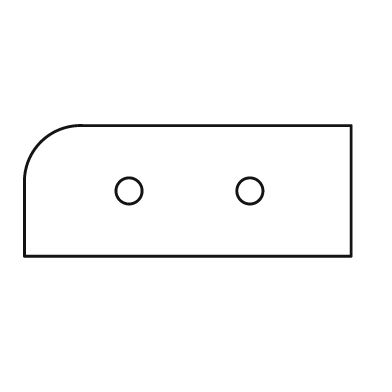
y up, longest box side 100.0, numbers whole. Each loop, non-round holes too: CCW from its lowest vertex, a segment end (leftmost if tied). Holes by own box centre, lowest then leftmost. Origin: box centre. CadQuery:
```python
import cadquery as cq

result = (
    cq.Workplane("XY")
    .moveTo(-50.0, -20.0)
    .lineTo(50.0, -20.0)
    .lineTo(50.0, 20.0)
    .lineTo(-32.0, 20.0)
    .threePointArc((-45.0, 15.0), (-50.0, 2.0))
    .close()
    .moveTo(-18.0, 0.0)
    .circle(4.0)
    .moveTo(19.0, 0.0)
    .circle(4.0)
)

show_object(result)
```